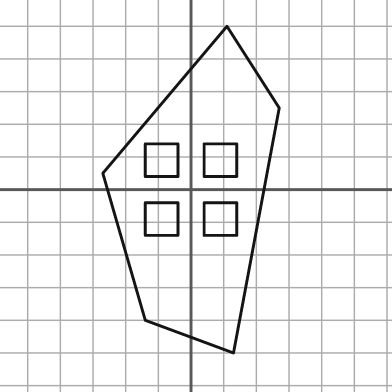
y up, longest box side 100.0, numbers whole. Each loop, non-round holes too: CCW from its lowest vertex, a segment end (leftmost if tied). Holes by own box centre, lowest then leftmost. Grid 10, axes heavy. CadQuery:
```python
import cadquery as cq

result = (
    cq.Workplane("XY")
    .moveTo(13.0, -50.0)
    .lineTo(27.0, 25.0)
    .lineTo(11.0, 50.0)
    .lineTo(-27.0, 5.0)
    .lineTo(-14.0, -40.0)
    .close()
    .moveTo(-14.0, -14.0)
    .lineTo(-4.0, -14.0)
    .lineTo(-4.0, -4.0)
    .lineTo(-14.0, -4.0)
    .close()
    .moveTo(4.0, -14.0)
    .lineTo(14.0, -14.0)
    .lineTo(14.0, -4.0)
    .lineTo(4.0, -4.0)
    .close()
    .moveTo(-14.0, 4.0)
    .lineTo(-4.0, 4.0)
    .lineTo(-4.0, 14.0)
    .lineTo(-14.0, 14.0)
    .close()
    .moveTo(4.0, 4.0)
    .lineTo(14.0, 4.0)
    .lineTo(14.0, 14.0)
    .lineTo(4.0, 14.0)
    .close()
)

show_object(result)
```